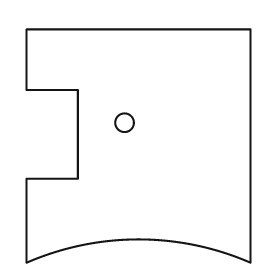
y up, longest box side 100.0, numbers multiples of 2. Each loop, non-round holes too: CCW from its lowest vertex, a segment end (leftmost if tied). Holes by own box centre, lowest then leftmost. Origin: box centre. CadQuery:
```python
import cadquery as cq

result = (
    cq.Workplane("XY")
    .moveTo(-48.0, -50.0)
    .threePointArc((0.0, -40.0), (48.0, -50.0))
    .lineTo(48.0, 50.0)
    .lineTo(-48.0, 50.0)
    .lineTo(-48.0, 24.0)
    .lineTo(-26.0, 24.0)
    .lineTo(-26.0, -14.0)
    .lineTo(-48.0, -14.0)
    .close()
    .moveTo(-6.0, 10.0)
    .circle(4.0)
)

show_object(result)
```